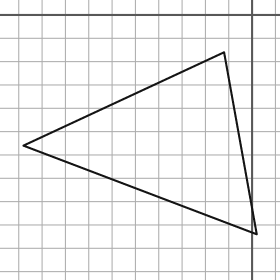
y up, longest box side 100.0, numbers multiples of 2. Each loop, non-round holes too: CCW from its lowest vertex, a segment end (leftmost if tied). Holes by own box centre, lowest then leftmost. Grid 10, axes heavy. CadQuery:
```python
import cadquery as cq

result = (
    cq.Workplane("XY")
    .moveTo(2.0, -94.0)
    .lineTo(-12.0, -16.0)
    .lineTo(-98.0, -56.0)
    .close()
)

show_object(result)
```